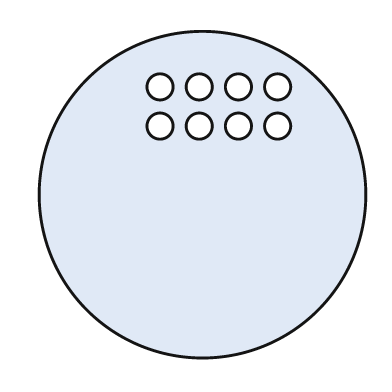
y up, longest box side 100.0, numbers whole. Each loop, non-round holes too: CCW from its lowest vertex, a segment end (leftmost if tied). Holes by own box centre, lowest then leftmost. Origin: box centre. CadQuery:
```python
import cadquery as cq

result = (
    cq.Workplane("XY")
    .moveTo(0.0, 0.0)
    .circle(50.0)
    .moveTo(-13.0, 21.0)
    .circle(4.0)
    .moveTo(-1.0, 21.0)
    .circle(4.0)
    .moveTo(11.0, 21.0)
    .circle(4.0)
    .moveTo(23.0, 21.0)
    .circle(4.0)
    .moveTo(-13.0, 33.0)
    .circle(4.0)
    .moveTo(-1.0, 33.0)
    .circle(4.0)
    .moveTo(11.0, 33.0)
    .circle(4.0)
    .moveTo(23.0, 33.0)
    .circle(4.0)
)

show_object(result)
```